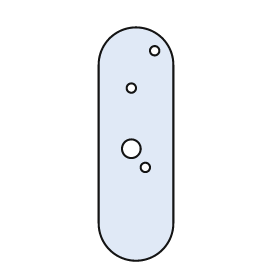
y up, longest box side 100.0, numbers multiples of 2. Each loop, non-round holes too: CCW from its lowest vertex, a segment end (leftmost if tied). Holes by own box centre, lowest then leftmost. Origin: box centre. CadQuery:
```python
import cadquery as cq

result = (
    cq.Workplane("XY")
    .moveTo(-16.0, -34.0)
    .threePointArc((0.0, -50.0), (16.0, -34.0))
    .lineTo(16.0, 34.0)
    .threePointArc((0.0, 50.0), (-16.0, 34.0))
    .close()
    .moveTo(4.0, -10.0)
    .circle(2.0)
    .moveTo(-2.0, -2.0)
    .circle(4.0)
    .moveTo(-2.0, 24.0)
    .circle(2.0)
    .moveTo(8.0, 40.0)
    .circle(2.0)
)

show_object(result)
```